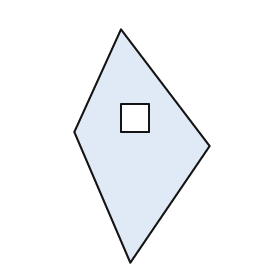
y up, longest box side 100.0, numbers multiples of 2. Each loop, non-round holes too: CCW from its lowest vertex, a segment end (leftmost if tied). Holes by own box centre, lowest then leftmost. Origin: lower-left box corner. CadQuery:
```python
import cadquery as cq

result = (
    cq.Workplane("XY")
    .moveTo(24.0, 0.0)
    .lineTo(58.0, 50.0)
    .lineTo(20.0, 100.0)
    .lineTo(0.0, 56.0)
    .close()
    .moveTo(20.0, 56.0)
    .lineTo(32.0, 56.0)
    .lineTo(32.0, 68.0)
    .lineTo(20.0, 68.0)
    .close()
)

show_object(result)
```